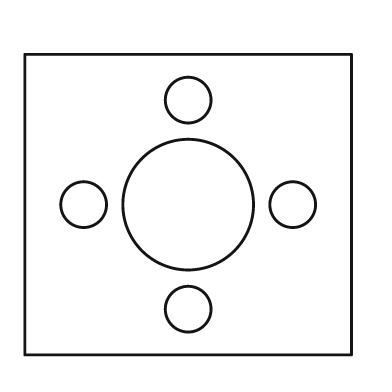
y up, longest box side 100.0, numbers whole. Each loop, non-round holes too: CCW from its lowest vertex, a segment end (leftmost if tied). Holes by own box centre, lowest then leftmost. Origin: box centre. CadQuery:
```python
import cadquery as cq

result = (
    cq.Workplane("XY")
    .moveTo(-50.0, -46.0)
    .lineTo(50.0, -46.0)
    .lineTo(50.0, 46.0)
    .lineTo(-50.0, 46.0)
    .close()
    .moveTo(0.0, -32.0)
    .circle(7.0)
    .moveTo(-32.0, 0.0)
    .circle(7.0)
    .moveTo(0.0, 0.0)
    .circle(20.0)
    .moveTo(32.0, 0.0)
    .circle(7.0)
    .moveTo(0.0, 32.0)
    .circle(7.0)
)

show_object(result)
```